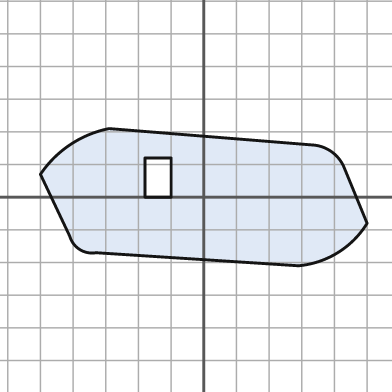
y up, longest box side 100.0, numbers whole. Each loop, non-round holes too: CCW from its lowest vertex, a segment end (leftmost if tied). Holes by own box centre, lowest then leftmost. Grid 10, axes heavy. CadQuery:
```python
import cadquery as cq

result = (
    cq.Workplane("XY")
    .moveTo(29.0, -21.0)
    .threePointArc((41.0, -17.0), (50.0, -8.0))
    .lineTo(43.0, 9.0)
    .threePointArc((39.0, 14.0), (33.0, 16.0))
    .lineTo(-29.0, 21.0)
    .threePointArc((-41.0, 16.0), (-50.0, 7.0))
    .lineTo(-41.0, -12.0)
    .threePointArc((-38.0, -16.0), (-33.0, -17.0))
    .close()
    .moveTo(-18.0, 0.0)
    .lineTo(-10.0, 0.0)
    .lineTo(-10.0, 12.0)
    .lineTo(-18.0, 12.0)
    .close()
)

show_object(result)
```